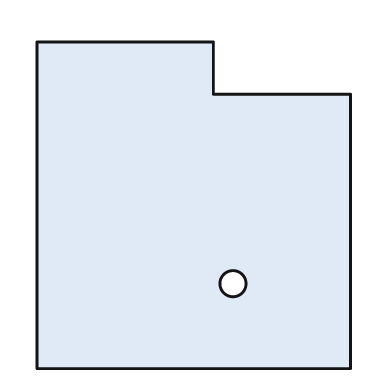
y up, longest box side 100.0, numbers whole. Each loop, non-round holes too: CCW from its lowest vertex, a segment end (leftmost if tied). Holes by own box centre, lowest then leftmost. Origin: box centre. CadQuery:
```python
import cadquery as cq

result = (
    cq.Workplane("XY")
    .moveTo(-48.0, -50.0)
    .lineTo(48.0, -50.0)
    .lineTo(48.0, 34.0)
    .lineTo(6.0, 34.0)
    .lineTo(6.0, 50.0)
    .lineTo(-48.0, 50.0)
    .close()
    .moveTo(12.0, -24.0)
    .circle(4.0)
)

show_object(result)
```